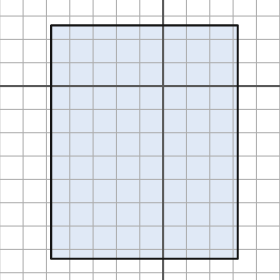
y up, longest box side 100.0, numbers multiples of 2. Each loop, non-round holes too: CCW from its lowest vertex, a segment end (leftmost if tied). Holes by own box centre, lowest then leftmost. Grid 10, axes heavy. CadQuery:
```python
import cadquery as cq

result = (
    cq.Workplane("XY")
    .moveTo(-48.0, -74.0)
    .lineTo(32.0, -74.0)
    .lineTo(32.0, 26.0)
    .lineTo(-48.0, 26.0)
    .close()
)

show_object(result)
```